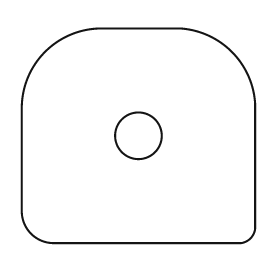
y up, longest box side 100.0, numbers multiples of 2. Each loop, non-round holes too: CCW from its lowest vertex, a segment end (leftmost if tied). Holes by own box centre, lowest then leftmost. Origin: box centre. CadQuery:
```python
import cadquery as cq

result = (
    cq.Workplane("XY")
    .moveTo(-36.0, -46.0)
    .lineTo(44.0, -46.0)
    .threePointArc((48.0, -44.0), (50.0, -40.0))
    .lineTo(50.0, 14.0)
    .threePointArc((40.0, 36.0), (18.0, 46.0))
    .lineTo(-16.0, 46.0)
    .threePointArc((-40.0, 36.0), (-50.0, 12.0))
    .lineTo(-50.0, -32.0)
    .threePointArc((-46.0, -42.0), (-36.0, -46.0))
    .close()
    .moveTo(0.0, 0.0)
    .circle(10.0)
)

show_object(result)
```